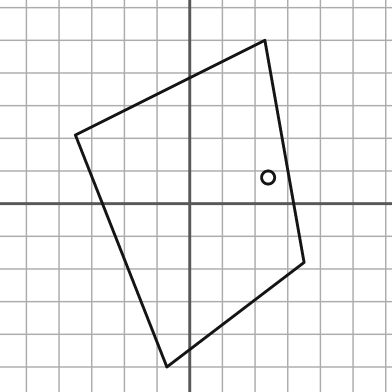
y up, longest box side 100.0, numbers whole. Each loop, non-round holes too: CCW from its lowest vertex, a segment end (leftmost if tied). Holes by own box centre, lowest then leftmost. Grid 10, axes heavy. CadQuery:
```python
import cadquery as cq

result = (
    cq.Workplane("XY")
    .moveTo(-7.0, -50.0)
    .lineTo(35.0, -18.0)
    .lineTo(23.0, 50.0)
    .lineTo(-35.0, 21.0)
    .close()
    .moveTo(24.0, 8.0)
    .circle(2.0)
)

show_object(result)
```